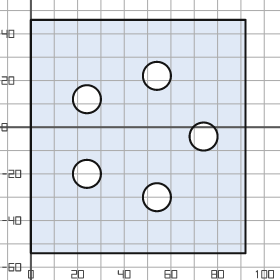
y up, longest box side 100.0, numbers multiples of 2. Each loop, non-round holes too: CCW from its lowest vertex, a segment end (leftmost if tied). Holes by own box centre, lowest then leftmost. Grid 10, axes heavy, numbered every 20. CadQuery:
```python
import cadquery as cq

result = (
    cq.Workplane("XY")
    .moveTo(0.0, -54.0)
    .lineTo(92.0, -54.0)
    .lineTo(92.0, 46.0)
    .lineTo(0.0, 46.0)
    .close()
    .moveTo(54.0, -30.0)
    .circle(6.0)
    .moveTo(24.0, -20.0)
    .circle(6.0)
    .moveTo(74.0, -4.0)
    .circle(6.0)
    .moveTo(24.0, 12.0)
    .circle(6.0)
    .moveTo(54.0, 22.0)
    .circle(6.0)
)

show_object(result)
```